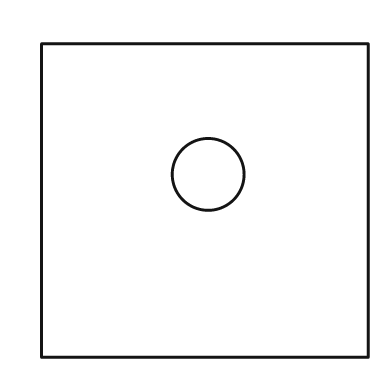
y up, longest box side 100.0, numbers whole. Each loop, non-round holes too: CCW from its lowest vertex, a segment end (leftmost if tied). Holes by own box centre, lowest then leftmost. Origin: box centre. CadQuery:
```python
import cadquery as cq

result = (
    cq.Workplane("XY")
    .moveTo(-50.0, -48.0)
    .lineTo(50.0, -48.0)
    .lineTo(50.0, 48.0)
    .lineTo(-50.0, 48.0)
    .close()
    .moveTo(1.0, 8.0)
    .circle(11.0)
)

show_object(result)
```